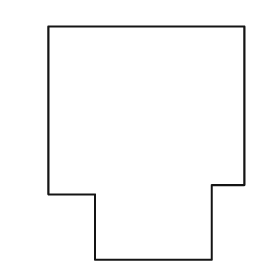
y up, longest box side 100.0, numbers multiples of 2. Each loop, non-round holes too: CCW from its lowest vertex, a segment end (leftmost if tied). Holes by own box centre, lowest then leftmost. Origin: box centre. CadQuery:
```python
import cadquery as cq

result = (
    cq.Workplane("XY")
    .moveTo(-22.0, -50.0)
    .lineTo(28.0, -50.0)
    .lineTo(28.0, -18.0)
    .lineTo(42.0, -18.0)
    .lineTo(42.0, 50.0)
    .lineTo(-42.0, 50.0)
    .lineTo(-42.0, -22.0)
    .lineTo(-22.0, -22.0)
    .close()
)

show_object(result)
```